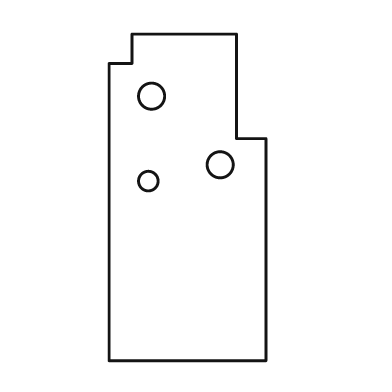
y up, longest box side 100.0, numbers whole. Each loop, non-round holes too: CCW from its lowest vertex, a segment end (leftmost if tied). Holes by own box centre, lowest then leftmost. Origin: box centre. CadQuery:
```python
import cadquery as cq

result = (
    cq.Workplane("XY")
    .moveTo(-24.0, -50.0)
    .lineTo(24.0, -50.0)
    .lineTo(24.0, 18.0)
    .lineTo(15.0, 18.0)
    .lineTo(15.0, 50.0)
    .lineTo(-17.0, 50.0)
    .lineTo(-17.0, 41.0)
    .lineTo(-24.0, 41.0)
    .close()
    .moveTo(-12.0, 5.0)
    .circle(3.0)
    .moveTo(10.0, 10.0)
    .circle(4.0)
    .moveTo(-11.0, 31.0)
    .circle(4.0)
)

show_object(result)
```